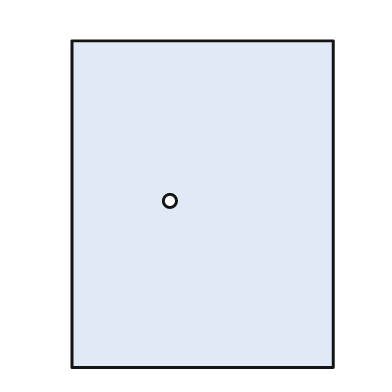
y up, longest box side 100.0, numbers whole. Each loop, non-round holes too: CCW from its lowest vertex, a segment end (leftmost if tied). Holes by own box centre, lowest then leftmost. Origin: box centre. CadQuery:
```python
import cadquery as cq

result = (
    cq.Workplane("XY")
    .moveTo(-40.0, -50.0)
    .lineTo(40.0, -50.0)
    .lineTo(40.0, 50.0)
    .lineTo(-40.0, 50.0)
    .close()
    .moveTo(-10.0, 1.0)
    .circle(2.0)
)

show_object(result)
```